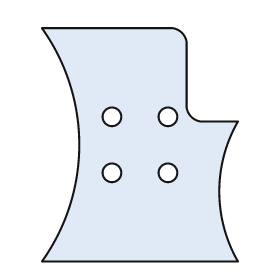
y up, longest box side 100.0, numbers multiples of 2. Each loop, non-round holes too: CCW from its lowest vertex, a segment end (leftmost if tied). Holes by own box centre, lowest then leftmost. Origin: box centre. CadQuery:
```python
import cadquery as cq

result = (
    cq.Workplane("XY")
    .moveTo(-42.0, -50.0)
    .lineTo(42.0, -50.0)
    .threePointArc((34.0, -20.0), (42.0, 10.0))
    .lineTo(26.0, 10.0)
    .threePointArc((22.0, 12.0), (20.0, 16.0))
    .lineTo(20.0, 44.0)
    .threePointArc((18.0, 48.0), (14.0, 50.0))
    .lineTo(-42.0, 50.0)
    .threePointArc((-26.0, 0.0), (-42.0, -50.0))
    .close()
    .moveTo(-12.0, -12.0)
    .circle(4.0)
    .moveTo(12.0, -12.0)
    .circle(4.0)
    .moveTo(-12.0, 12.0)
    .circle(4.0)
    .moveTo(12.0, 12.0)
    .circle(4.0)
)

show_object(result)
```